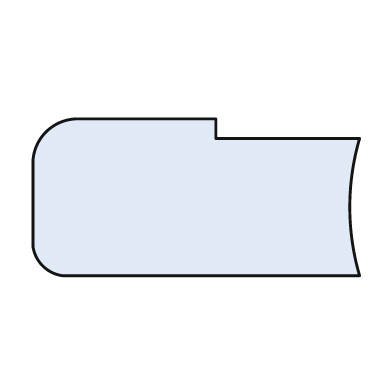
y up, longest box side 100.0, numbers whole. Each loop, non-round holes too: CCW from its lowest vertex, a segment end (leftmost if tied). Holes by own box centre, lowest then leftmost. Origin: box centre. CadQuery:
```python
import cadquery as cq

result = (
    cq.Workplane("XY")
    .moveTo(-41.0, -24.0)
    .lineTo(50.0, -24.0)
    .threePointArc((47.0, -3.0), (50.0, 18.0))
    .lineTo(6.0, 18.0)
    .lineTo(6.0, 24.0)
    .lineTo(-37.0, 24.0)
    .threePointArc((-46.0, 20.0), (-50.0, 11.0))
    .lineTo(-50.0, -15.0)
    .threePointArc((-47.0, -21.0), (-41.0, -24.0))
    .close()
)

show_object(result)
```